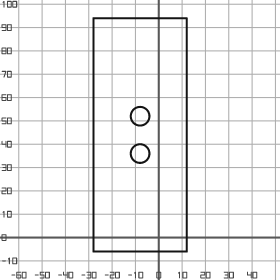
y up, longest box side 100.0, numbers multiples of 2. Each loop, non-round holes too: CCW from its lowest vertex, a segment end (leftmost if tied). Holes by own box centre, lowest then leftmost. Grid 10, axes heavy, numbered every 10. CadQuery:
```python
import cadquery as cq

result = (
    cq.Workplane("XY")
    .moveTo(-28.0, -6.0)
    .lineTo(12.0, -6.0)
    .lineTo(12.0, 94.0)
    .lineTo(-28.0, 94.0)
    .close()
    .moveTo(-8.0, 36.0)
    .circle(4.0)
    .moveTo(-8.0, 52.0)
    .circle(4.0)
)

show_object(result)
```